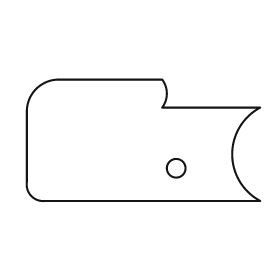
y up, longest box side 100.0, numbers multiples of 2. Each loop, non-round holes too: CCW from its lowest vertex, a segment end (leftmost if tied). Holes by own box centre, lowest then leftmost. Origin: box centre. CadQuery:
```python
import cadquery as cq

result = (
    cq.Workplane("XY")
    .moveTo(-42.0, -26.0)
    .lineTo(50.0, -26.0)
    .threePointArc((38.0, -6.0), (50.0, 14.0))
    .lineTo(8.0, 14.0)
    .threePointArc((10.0, 20.0), (8.0, 26.0))
    .lineTo(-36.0, 26.0)
    .threePointArc((-46.0, 22.0), (-50.0, 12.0))
    .lineTo(-50.0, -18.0)
    .threePointArc((-48.0, -24.0), (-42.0, -26.0))
    .close()
    .moveTo(14.0, -12.0)
    .circle(4.0)
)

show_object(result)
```